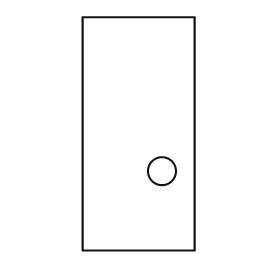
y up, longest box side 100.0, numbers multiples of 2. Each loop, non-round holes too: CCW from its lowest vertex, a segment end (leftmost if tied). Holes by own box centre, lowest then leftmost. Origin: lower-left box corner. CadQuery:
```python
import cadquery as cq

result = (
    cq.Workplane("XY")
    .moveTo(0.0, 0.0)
    .lineTo(48.0, 0.0)
    .lineTo(48.0, 100.0)
    .lineTo(0.0, 100.0)
    .close()
    .moveTo(34.0, 34.0)
    .circle(6.0)
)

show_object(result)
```